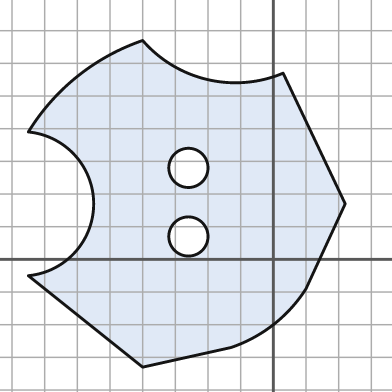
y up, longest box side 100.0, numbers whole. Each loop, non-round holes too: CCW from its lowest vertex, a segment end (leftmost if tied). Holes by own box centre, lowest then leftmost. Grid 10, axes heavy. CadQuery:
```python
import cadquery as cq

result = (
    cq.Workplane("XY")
    .moveTo(-40.0, -33.0)
    .lineTo(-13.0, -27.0)
    .threePointArc((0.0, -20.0), (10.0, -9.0))
    .lineTo(22.0, 17.0)
    .lineTo(3.0, 57.0)
    .threePointArc((-20.0, 55.0), (-40.0, 67.0))
    .threePointArc((-60.0, 56.0), (-75.0, 39.0))
    .threePointArc((-55.0, 17.0), (-75.0, -5.0))
    .close()
    .moveTo(-26.0, 7.0)
    .circle(6.0)
    .moveTo(-26.0, 28.0)
    .circle(6.0)
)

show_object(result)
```